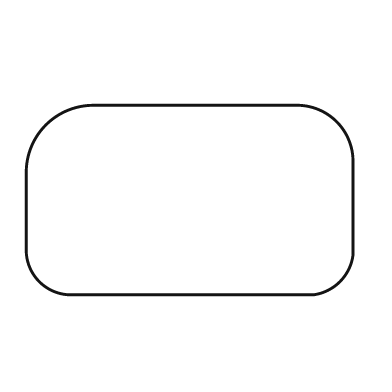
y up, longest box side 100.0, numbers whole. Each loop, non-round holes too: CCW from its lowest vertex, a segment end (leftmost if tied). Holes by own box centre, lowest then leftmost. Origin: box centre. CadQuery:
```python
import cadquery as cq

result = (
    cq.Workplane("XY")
    .moveTo(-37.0, -29.0)
    .lineTo(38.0, -29.0)
    .threePointArc((46.0, -25.0), (50.0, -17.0))
    .lineTo(50.0, 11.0)
    .threePointArc((45.0, 24.0), (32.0, 29.0))
    .lineTo(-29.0, 29.0)
    .threePointArc((-44.0, 23.0), (-50.0, 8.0))
    .lineTo(-50.0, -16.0)
    .threePointArc((-46.0, -25.0), (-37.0, -29.0))
    .close()
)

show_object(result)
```